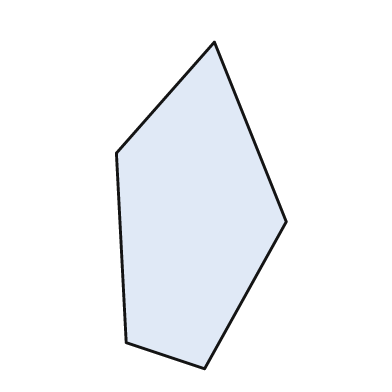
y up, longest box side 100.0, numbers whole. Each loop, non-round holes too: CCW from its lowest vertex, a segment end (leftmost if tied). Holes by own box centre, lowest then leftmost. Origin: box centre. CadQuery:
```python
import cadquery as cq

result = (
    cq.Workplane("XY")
    .moveTo(1.0, -50.0)
    .lineTo(26.0, -5.0)
    .lineTo(4.0, 50.0)
    .lineTo(-26.0, 16.0)
    .lineTo(-23.0, -42.0)
    .close()
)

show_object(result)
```